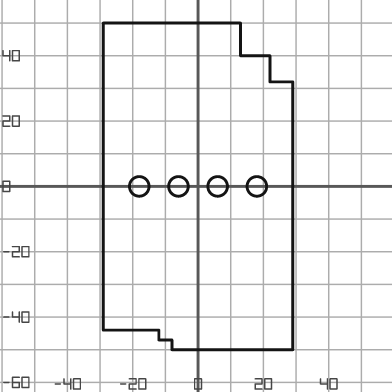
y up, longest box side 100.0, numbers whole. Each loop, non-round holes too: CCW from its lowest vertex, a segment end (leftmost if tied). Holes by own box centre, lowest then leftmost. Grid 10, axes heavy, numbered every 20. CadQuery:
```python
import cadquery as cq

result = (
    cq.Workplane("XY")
    .moveTo(-8.0, -50.0)
    .lineTo(29.0, -50.0)
    .lineTo(29.0, 32.0)
    .lineTo(22.0, 32.0)
    .lineTo(22.0, 40.0)
    .lineTo(13.0, 40.0)
    .lineTo(13.0, 50.0)
    .lineTo(-29.0, 50.0)
    .lineTo(-29.0, -44.0)
    .lineTo(-12.0, -44.0)
    .lineTo(-12.0, -47.0)
    .lineTo(-8.0, -47.0)
    .close()
    .moveTo(-18.0, 0.0)
    .circle(3.0)
    .moveTo(-6.0, 0.0)
    .circle(3.0)
    .moveTo(6.0, 0.0)
    .circle(3.0)
    .moveTo(18.0, 0.0)
    .circle(3.0)
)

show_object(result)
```